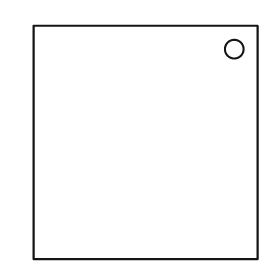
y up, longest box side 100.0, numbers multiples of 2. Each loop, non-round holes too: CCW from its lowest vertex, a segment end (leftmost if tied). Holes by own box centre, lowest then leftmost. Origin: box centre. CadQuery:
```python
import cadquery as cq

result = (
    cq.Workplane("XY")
    .moveTo(-48.0, -50.0)
    .lineTo(48.0, -50.0)
    .lineTo(48.0, 50.0)
    .lineTo(-48.0, 50.0)
    .close()
    .moveTo(38.0, 40.0)
    .circle(4.0)
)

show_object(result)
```